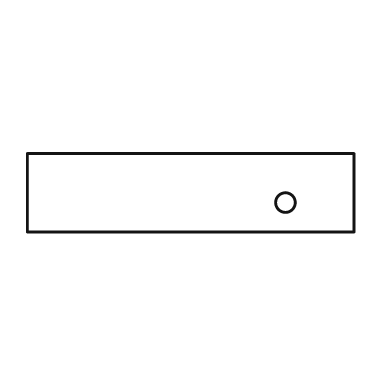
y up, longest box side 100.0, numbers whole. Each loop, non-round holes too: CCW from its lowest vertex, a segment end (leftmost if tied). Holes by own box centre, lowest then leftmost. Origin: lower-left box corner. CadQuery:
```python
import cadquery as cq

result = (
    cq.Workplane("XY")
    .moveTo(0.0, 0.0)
    .lineTo(100.0, 0.0)
    .lineTo(100.0, 24.0)
    .lineTo(0.0, 24.0)
    .close()
    .moveTo(79.0, 9.0)
    .circle(3.0)
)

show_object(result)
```